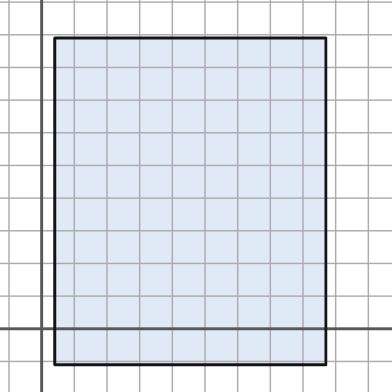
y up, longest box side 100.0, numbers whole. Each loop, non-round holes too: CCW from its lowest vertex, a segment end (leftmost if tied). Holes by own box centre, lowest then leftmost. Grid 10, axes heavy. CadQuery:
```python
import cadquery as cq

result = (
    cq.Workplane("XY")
    .moveTo(4.0, -11.0)
    .lineTo(87.0, -11.0)
    .lineTo(87.0, 89.0)
    .lineTo(4.0, 89.0)
    .close()
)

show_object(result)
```